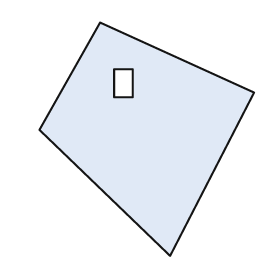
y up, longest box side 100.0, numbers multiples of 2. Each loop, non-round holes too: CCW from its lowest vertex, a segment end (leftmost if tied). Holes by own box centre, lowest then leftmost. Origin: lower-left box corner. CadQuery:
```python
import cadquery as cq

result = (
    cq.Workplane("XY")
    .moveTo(56.0, 0.0)
    .lineTo(92.0, 70.0)
    .lineTo(26.0, 100.0)
    .lineTo(0.0, 54.0)
    .close()
    .moveTo(32.0, 68.0)
    .lineTo(40.0, 68.0)
    .lineTo(40.0, 80.0)
    .lineTo(32.0, 80.0)
    .close()
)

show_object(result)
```